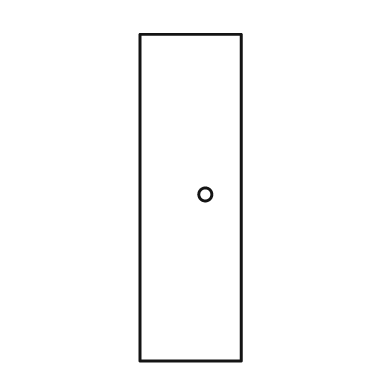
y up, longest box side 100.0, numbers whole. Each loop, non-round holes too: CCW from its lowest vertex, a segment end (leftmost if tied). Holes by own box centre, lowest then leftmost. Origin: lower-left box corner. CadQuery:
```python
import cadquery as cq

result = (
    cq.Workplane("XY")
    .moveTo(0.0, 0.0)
    .lineTo(31.0, 0.0)
    .lineTo(31.0, 100.0)
    .lineTo(0.0, 100.0)
    .close()
    .moveTo(20.0, 51.0)
    .circle(2.0)
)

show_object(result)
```